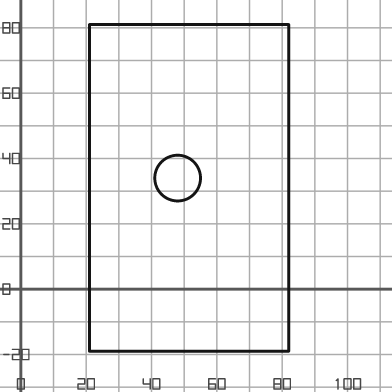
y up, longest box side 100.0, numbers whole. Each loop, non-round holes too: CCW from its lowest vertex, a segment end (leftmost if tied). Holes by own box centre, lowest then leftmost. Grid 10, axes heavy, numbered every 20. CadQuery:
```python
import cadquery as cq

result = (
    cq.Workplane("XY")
    .moveTo(21.0, -19.0)
    .lineTo(82.0, -19.0)
    .lineTo(82.0, 81.0)
    .lineTo(21.0, 81.0)
    .close()
    .moveTo(48.0, 34.0)
    .circle(7.0)
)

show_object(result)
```